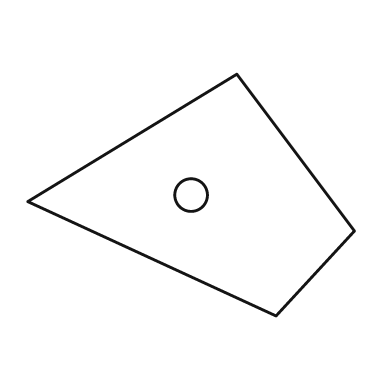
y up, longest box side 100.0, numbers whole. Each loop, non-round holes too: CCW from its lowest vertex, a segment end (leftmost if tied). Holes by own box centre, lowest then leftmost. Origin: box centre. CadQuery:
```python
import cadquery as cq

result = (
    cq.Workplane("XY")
    .moveTo(26.0, -37.0)
    .lineTo(50.0, -11.0)
    .lineTo(14.0, 37.0)
    .lineTo(-50.0, -2.0)
    .close()
    .moveTo(0.0, 0.0)
    .circle(5.0)
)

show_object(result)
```